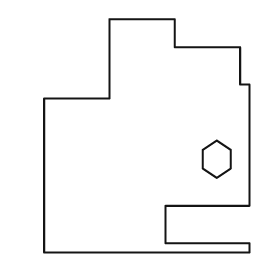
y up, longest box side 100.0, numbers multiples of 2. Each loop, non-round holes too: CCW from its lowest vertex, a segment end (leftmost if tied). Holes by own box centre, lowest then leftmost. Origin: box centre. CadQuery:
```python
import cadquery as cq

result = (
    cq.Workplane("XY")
    .moveTo(-44.0, -50.0)
    .lineTo(44.0, -50.0)
    .lineTo(44.0, -46.0)
    .lineTo(8.0, -46.0)
    .lineTo(8.0, -30.0)
    .lineTo(44.0, -30.0)
    .lineTo(44.0, 22.0)
    .lineTo(40.0, 22.0)
    .lineTo(40.0, 38.0)
    .lineTo(12.0, 38.0)
    .lineTo(12.0, 50.0)
    .lineTo(-16.0, 50.0)
    .lineTo(-16.0, 16.0)
    .lineTo(-44.0, 16.0)
    .close()
    .moveTo(30.0, -18.0)
    .lineTo(36.0, -14.0)
    .lineTo(36.0, -6.0)
    .lineTo(30.0, -2.0)
    .lineTo(24.0, -6.0)
    .lineTo(24.0, -14.0)
    .close()
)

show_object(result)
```